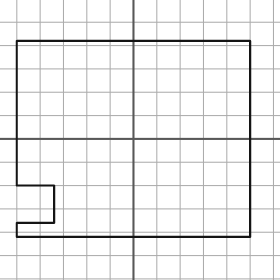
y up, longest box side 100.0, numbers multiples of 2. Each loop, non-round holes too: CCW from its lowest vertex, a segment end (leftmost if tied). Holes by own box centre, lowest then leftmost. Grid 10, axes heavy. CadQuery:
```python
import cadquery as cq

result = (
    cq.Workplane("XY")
    .moveTo(-50.0, -42.0)
    .lineTo(50.0, -42.0)
    .lineTo(50.0, 42.0)
    .lineTo(-50.0, 42.0)
    .lineTo(-50.0, -20.0)
    .lineTo(-34.0, -20.0)
    .lineTo(-34.0, -36.0)
    .lineTo(-50.0, -36.0)
    .close()
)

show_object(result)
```